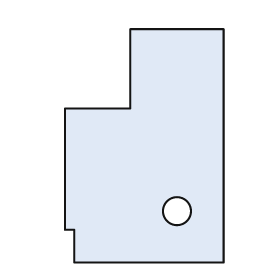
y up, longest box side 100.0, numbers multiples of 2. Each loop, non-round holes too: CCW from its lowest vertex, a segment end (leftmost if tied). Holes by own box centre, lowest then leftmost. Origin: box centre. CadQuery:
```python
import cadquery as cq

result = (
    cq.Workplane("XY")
    .moveTo(-30.0, -50.0)
    .lineTo(34.0, -50.0)
    .lineTo(34.0, 50.0)
    .lineTo(-6.0, 50.0)
    .lineTo(-6.0, 16.0)
    .lineTo(-34.0, 16.0)
    .lineTo(-34.0, -36.0)
    .lineTo(-30.0, -36.0)
    .close()
    .moveTo(14.0, -28.0)
    .circle(6.0)
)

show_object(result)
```